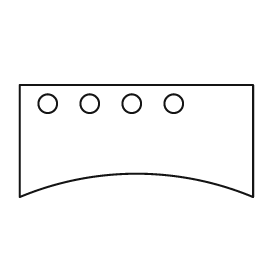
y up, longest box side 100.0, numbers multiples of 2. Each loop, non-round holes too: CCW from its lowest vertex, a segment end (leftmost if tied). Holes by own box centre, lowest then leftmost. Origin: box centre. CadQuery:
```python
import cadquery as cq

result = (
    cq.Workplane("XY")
    .moveTo(-50.0, -24.0)
    .threePointArc((0.0, -14.0), (50.0, -24.0))
    .lineTo(50.0, 24.0)
    .lineTo(-50.0, 24.0)
    .close()
    .moveTo(-38.0, 16.0)
    .circle(4.0)
    .moveTo(-20.0, 16.0)
    .circle(4.0)
    .moveTo(-2.0, 16.0)
    .circle(4.0)
    .moveTo(16.0, 16.0)
    .circle(4.0)
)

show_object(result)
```